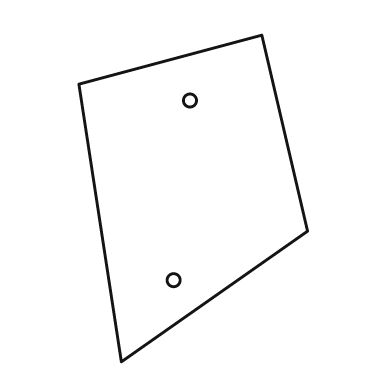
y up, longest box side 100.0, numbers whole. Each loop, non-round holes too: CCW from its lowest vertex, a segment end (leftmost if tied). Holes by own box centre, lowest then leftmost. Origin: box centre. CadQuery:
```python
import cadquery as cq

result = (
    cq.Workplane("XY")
    .moveTo(-22.0, -50.0)
    .lineTo(35.0, -10.0)
    .lineTo(21.0, 50.0)
    .lineTo(-35.0, 35.0)
    .close()
    .moveTo(-6.0, -25.0)
    .circle(2.0)
    .moveTo(-1.0, 30.0)
    .circle(2.0)
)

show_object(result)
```